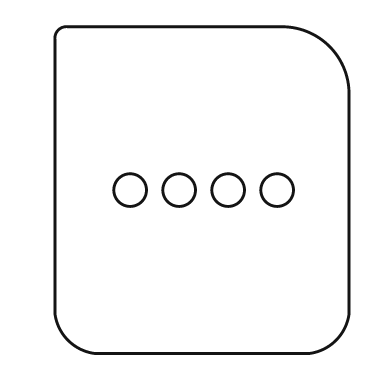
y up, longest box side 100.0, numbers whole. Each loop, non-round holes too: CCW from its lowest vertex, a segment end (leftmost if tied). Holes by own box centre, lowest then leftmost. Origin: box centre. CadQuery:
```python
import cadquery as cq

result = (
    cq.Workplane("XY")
    .moveTo(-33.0, -50.0)
    .lineTo(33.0, -50.0)
    .threePointArc((41.0, -46.0), (45.0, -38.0))
    .lineTo(45.0, 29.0)
    .threePointArc((39.0, 44.0), (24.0, 50.0))
    .lineTo(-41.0, 50.0)
    .threePointArc((-44.0, 49.0), (-45.0, 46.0))
    .lineTo(-45.0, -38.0)
    .threePointArc((-41.0, -46.0), (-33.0, -50.0))
    .close()
    .moveTo(-22.0, 0.0)
    .circle(5.0)
    .moveTo(-7.0, 0.0)
    .circle(5.0)
    .moveTo(8.0, 0.0)
    .circle(5.0)
    .moveTo(23.0, 0.0)
    .circle(5.0)
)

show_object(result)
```